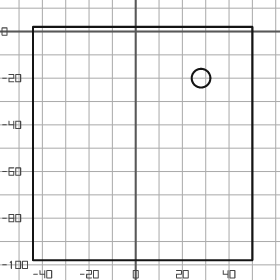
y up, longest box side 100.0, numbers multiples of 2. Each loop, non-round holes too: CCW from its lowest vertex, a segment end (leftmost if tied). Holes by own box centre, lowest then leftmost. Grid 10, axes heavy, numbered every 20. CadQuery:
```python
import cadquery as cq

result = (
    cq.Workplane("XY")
    .moveTo(-44.0, -98.0)
    .lineTo(50.0, -98.0)
    .lineTo(50.0, 2.0)
    .lineTo(-44.0, 2.0)
    .close()
    .moveTo(28.0, -20.0)
    .circle(4.0)
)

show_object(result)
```